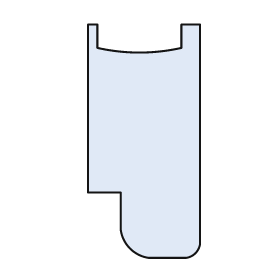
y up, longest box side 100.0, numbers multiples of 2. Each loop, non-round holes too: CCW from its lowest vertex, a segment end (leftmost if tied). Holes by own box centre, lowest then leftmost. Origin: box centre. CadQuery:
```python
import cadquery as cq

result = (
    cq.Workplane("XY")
    .moveTo(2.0, -50.0)
    .lineTo(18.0, -50.0)
    .threePointArc((22.0, -48.0), (24.0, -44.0))
    .lineTo(24.0, 50.0)
    .lineTo(16.0, 50.0)
    .lineTo(16.0, 40.0)
    .threePointArc((-2.0, 38.0), (-20.0, 40.0))
    .lineTo(-20.0, 50.0)
    .lineTo(-24.0, 50.0)
    .lineTo(-24.0, -22.0)
    .lineTo(-10.0, -22.0)
    .lineTo(-10.0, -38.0)
    .threePointArc((-6.0, -46.0), (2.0, -50.0))
    .close()
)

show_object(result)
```